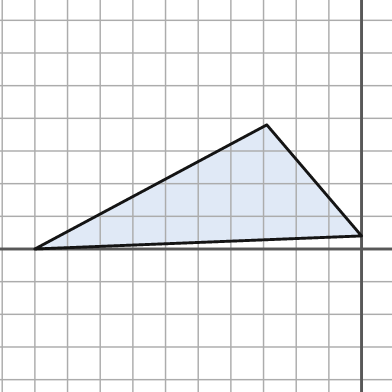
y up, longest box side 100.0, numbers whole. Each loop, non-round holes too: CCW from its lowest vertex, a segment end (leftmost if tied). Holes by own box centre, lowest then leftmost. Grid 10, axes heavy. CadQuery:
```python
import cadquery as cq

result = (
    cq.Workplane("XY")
    .moveTo(-100.0, 0.0)
    .lineTo(0.0, 4.0)
    .lineTo(-29.0, 38.0)
    .close()
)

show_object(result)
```